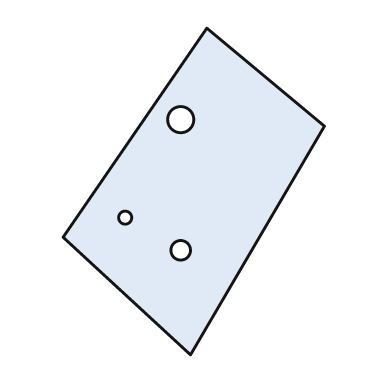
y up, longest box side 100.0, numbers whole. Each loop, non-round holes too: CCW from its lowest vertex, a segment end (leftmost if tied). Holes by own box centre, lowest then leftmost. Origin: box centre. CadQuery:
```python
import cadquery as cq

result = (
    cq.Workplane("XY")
    .moveTo(-1.0, -50.0)
    .lineTo(40.0, 20.0)
    .lineTo(4.0, 50.0)
    .lineTo(-40.0, -14.0)
    .close()
    .moveTo(-4.0, -18.0)
    .circle(3.0)
    .moveTo(-21.0, -8.0)
    .circle(2.0)
    .moveTo(-4.0, 22.0)
    .circle(4.0)
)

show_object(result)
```